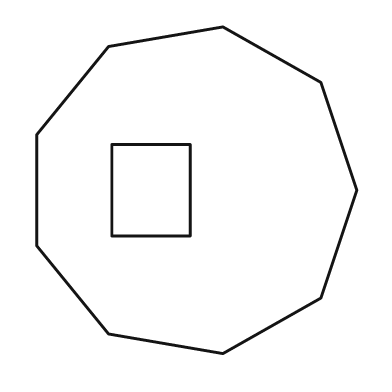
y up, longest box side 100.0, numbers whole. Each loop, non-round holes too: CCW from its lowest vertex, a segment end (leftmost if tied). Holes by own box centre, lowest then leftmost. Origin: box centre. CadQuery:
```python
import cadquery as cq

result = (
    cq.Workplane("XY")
    .moveTo(8.0, -50.0)
    .lineTo(38.0, -33.0)
    .lineTo(49.0, 0.0)
    .lineTo(38.0, 33.0)
    .lineTo(8.0, 50.0)
    .lineTo(-27.0, 44.0)
    .lineTo(-49.0, 17.0)
    .lineTo(-49.0, -17.0)
    .lineTo(-27.0, -44.0)
    .close()
    .moveTo(-26.0, -14.0)
    .lineTo(-2.0, -14.0)
    .lineTo(-2.0, 14.0)
    .lineTo(-26.0, 14.0)
    .close()
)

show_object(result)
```